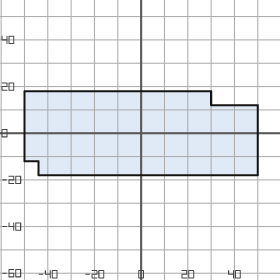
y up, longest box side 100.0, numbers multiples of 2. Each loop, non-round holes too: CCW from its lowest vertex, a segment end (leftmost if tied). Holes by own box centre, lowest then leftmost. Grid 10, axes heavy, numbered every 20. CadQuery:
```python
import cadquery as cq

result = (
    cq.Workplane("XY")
    .moveTo(-44.0, -18.0)
    .lineTo(50.0, -18.0)
    .lineTo(50.0, 12.0)
    .lineTo(30.0, 12.0)
    .lineTo(30.0, 18.0)
    .lineTo(-50.0, 18.0)
    .lineTo(-50.0, -12.0)
    .lineTo(-44.0, -12.0)
    .close()
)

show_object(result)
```